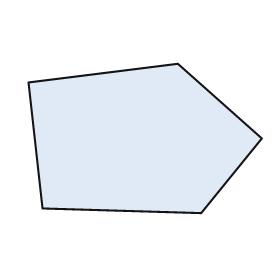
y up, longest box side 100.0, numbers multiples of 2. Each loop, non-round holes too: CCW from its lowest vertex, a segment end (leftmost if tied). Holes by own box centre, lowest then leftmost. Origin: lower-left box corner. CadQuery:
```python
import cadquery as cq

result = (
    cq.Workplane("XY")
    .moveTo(74.0, 0.0)
    .lineTo(100.0, 32.0)
    .lineTo(64.0, 64.0)
    .lineTo(0.0, 56.0)
    .lineTo(6.0, 2.0)
    .close()
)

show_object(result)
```